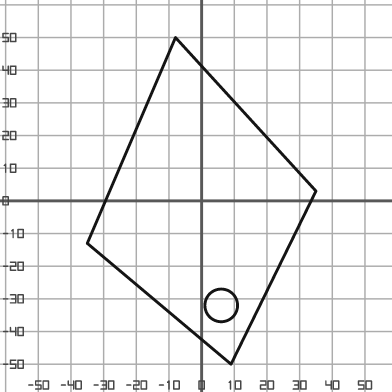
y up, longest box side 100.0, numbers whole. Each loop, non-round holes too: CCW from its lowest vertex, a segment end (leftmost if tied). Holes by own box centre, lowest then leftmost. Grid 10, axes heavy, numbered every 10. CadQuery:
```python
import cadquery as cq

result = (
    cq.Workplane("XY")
    .moveTo(9.0, -50.0)
    .lineTo(35.0, 3.0)
    .lineTo(-8.0, 50.0)
    .lineTo(-35.0, -13.0)
    .close()
    .moveTo(6.0, -32.0)
    .circle(5.0)
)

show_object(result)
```